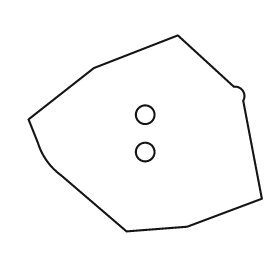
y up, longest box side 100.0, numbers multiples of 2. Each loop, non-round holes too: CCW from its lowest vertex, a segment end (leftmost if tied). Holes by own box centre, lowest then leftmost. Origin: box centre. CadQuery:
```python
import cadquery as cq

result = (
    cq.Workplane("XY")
    .moveTo(-8.0, -42.0)
    .lineTo(18.0, -40.0)
    .lineTo(50.0, -28.0)
    .lineTo(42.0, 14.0)
    .threePointArc((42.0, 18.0), (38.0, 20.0))
    .lineTo(14.0, 42.0)
    .lineTo(-22.0, 28.0)
    .lineTo(-50.0, 6.0)
    .lineTo(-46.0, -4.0)
    .threePointArc((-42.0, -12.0), (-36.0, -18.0))
    .close()
    .moveTo(0.0, -8.0)
    .circle(4.0)
    .moveTo(0.0, 8.0)
    .circle(4.0)
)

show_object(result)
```